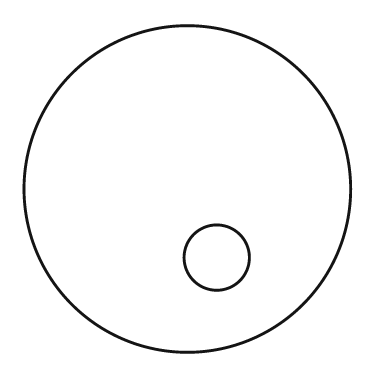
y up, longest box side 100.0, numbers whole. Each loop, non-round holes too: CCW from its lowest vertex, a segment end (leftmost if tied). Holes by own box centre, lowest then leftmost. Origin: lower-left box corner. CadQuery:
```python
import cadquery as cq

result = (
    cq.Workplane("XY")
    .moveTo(50.0, 50.0)
    .circle(50.0)
    .moveTo(59.0, 29.0)
    .circle(10.0)
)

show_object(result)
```